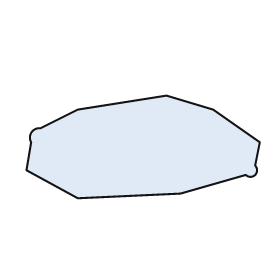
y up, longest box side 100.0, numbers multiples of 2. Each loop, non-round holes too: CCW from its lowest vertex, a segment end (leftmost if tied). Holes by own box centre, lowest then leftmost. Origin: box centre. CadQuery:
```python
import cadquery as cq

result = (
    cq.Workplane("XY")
    .moveTo(-28.0, -22.0)
    .lineTo(16.0, -20.0)
    .lineTo(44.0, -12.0)
    .threePointArc((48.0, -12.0), (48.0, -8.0))
    .lineTo(50.0, 2.0)
    .lineTo(30.0, 16.0)
    .lineTo(10.0, 22.0)
    .lineTo(-28.0, 16.0)
    .lineTo(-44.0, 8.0)
    .threePointArc((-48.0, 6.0), (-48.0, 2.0))
    .lineTo(-50.0, -10.0)
    .close()
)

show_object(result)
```